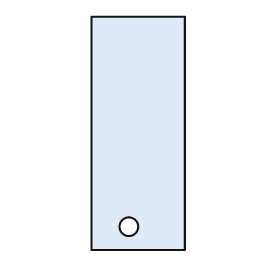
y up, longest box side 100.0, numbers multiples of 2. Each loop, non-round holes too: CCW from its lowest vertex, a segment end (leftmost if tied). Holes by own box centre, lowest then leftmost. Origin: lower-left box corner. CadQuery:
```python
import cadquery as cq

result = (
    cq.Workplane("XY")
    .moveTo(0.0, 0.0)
    .lineTo(40.0, 0.0)
    .lineTo(40.0, 100.0)
    .lineTo(0.0, 100.0)
    .close()
    .moveTo(16.0, 10.0)
    .circle(4.0)
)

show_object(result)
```